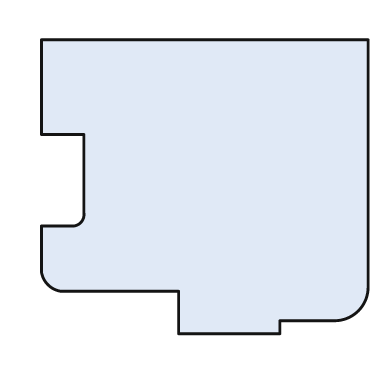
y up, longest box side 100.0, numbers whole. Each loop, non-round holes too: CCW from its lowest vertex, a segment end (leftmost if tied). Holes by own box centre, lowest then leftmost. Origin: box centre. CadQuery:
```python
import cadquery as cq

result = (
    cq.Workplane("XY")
    .moveTo(-8.0, -45.0)
    .lineTo(23.0, -45.0)
    .lineTo(23.0, -41.0)
    .lineTo(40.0, -41.0)
    .threePointArc((47.0, -38.0), (50.0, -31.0))
    .lineTo(50.0, 45.0)
    .lineTo(-50.0, 45.0)
    .lineTo(-50.0, 16.0)
    .lineTo(-37.0, 16.0)
    .lineTo(-37.0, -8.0)
    .threePointArc((-38.0, -11.0), (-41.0, -12.0))
    .lineTo(-50.0, -12.0)
    .lineTo(-50.0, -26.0)
    .threePointArc((-48.0, -30.0), (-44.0, -32.0))
    .lineTo(-8.0, -32.0)
    .close()
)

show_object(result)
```